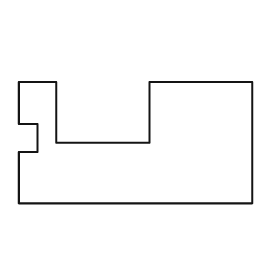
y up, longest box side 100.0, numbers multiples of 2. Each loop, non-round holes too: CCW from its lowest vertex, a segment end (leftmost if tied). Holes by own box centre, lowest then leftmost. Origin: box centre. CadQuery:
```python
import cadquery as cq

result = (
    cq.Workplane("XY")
    .moveTo(-50.0, -26.0)
    .lineTo(50.0, -26.0)
    .lineTo(50.0, 26.0)
    .lineTo(6.0, 26.0)
    .lineTo(6.0, 0.0)
    .lineTo(-34.0, 0.0)
    .lineTo(-34.0, 26.0)
    .lineTo(-50.0, 26.0)
    .lineTo(-50.0, 8.0)
    .lineTo(-42.0, 8.0)
    .lineTo(-42.0, -4.0)
    .lineTo(-50.0, -4.0)
    .close()
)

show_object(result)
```